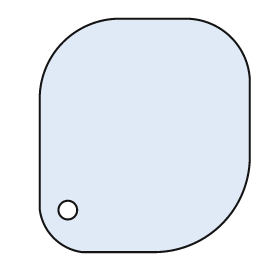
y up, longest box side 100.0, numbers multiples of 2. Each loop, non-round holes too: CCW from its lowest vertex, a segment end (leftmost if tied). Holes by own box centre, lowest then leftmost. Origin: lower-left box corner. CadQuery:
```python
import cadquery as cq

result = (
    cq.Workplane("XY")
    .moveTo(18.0, 0.0)
    .lineTo(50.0, 0.0)
    .threePointArc((78.0, 12.0), (90.0, 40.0))
    .lineTo(90.0, 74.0)
    .threePointArc((82.0, 92.0), (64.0, 100.0))
    .lineTo(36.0, 100.0)
    .threePointArc((10.0, 90.0), (0.0, 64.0))
    .lineTo(0.0, 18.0)
    .threePointArc((6.0, 6.0), (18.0, 0.0))
    .close()
    .moveTo(12.0, 18.0)
    .circle(4.0)
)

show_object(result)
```